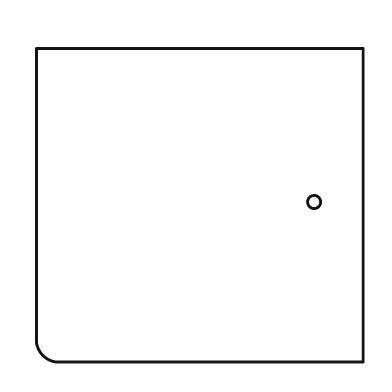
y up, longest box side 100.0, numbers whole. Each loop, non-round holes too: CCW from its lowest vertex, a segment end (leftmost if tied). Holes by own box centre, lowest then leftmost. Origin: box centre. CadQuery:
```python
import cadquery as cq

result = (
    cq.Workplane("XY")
    .moveTo(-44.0, -48.0)
    .lineTo(50.0, -48.0)
    .lineTo(50.0, 48.0)
    .lineTo(-50.0, 48.0)
    .lineTo(-50.0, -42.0)
    .threePointArc((-48.0, -46.0), (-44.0, -48.0))
    .close()
    .moveTo(35.0, 1.0)
    .circle(2.0)
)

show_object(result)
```